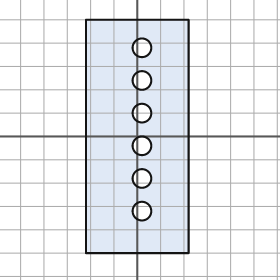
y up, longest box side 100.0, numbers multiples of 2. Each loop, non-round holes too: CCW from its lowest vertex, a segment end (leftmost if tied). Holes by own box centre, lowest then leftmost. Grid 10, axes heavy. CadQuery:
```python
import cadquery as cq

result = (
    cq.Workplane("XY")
    .moveTo(-22.0, -50.0)
    .lineTo(22.0, -50.0)
    .lineTo(22.0, 50.0)
    .lineTo(-22.0, 50.0)
    .close()
    .moveTo(2.0, -32.0)
    .circle(4.0)
    .moveTo(2.0, -18.0)
    .circle(4.0)
    .moveTo(2.0, -4.0)
    .circle(4.0)
    .moveTo(2.0, 10.0)
    .circle(4.0)
    .moveTo(2.0, 24.0)
    .circle(4.0)
    .moveTo(2.0, 38.0)
    .circle(4.0)
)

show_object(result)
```